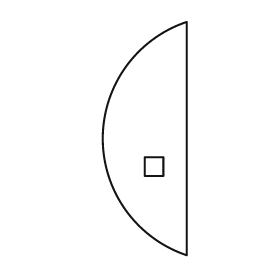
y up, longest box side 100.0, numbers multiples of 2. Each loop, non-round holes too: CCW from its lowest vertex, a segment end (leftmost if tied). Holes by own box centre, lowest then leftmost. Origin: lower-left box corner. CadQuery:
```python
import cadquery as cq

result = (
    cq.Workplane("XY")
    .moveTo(36.0, 0.0)
    .lineTo(36.0, 100.0)
    .threePointArc((0.0, 50.0), (36.0, 0.0))
    .close()
    .moveTo(18.0, 34.0)
    .lineTo(26.0, 34.0)
    .lineTo(26.0, 42.0)
    .lineTo(18.0, 42.0)
    .close()
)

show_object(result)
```